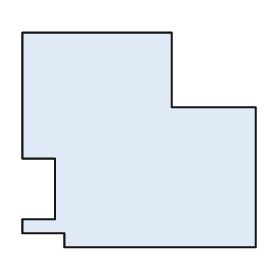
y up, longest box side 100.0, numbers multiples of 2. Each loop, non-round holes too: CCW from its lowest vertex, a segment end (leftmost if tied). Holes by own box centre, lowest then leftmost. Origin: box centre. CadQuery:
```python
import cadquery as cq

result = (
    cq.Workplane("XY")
    .moveTo(-32.0, -46.0)
    .lineTo(50.0, -46.0)
    .lineTo(50.0, 14.0)
    .lineTo(14.0, 14.0)
    .lineTo(14.0, 46.0)
    .lineTo(-50.0, 46.0)
    .lineTo(-50.0, -8.0)
    .lineTo(-36.0, -8.0)
    .lineTo(-36.0, -34.0)
    .lineTo(-50.0, -34.0)
    .lineTo(-50.0, -40.0)
    .lineTo(-32.0, -40.0)
    .close()
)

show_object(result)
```